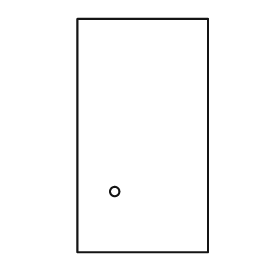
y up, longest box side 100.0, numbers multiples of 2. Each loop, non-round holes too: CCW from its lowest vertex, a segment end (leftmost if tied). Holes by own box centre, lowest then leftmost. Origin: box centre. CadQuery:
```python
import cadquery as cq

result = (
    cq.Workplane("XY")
    .moveTo(-28.0, -50.0)
    .lineTo(28.0, -50.0)
    .lineTo(28.0, 50.0)
    .lineTo(-28.0, 50.0)
    .close()
    .moveTo(-12.0, -24.0)
    .circle(2.0)
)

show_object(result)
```